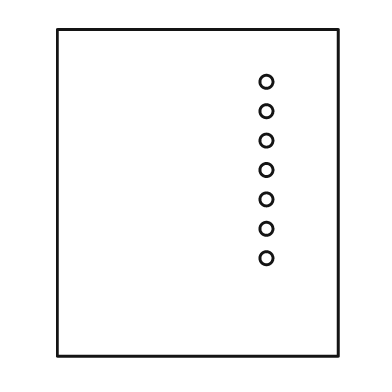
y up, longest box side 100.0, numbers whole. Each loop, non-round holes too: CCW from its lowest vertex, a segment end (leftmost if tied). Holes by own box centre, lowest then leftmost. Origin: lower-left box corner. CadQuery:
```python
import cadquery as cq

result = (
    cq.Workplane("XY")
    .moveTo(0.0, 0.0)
    .lineTo(86.0, 0.0)
    .lineTo(86.0, 100.0)
    .lineTo(0.0, 100.0)
    .close()
    .moveTo(64.0, 30.0)
    .circle(2.0)
    .moveTo(64.0, 39.0)
    .circle(2.0)
    .moveTo(64.0, 48.0)
    .circle(2.0)
    .moveTo(64.0, 57.0)
    .circle(2.0)
    .moveTo(64.0, 66.0)
    .circle(2.0)
    .moveTo(64.0, 75.0)
    .circle(2.0)
    .moveTo(64.0, 84.0)
    .circle(2.0)
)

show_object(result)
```